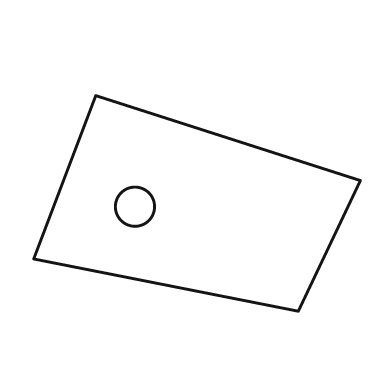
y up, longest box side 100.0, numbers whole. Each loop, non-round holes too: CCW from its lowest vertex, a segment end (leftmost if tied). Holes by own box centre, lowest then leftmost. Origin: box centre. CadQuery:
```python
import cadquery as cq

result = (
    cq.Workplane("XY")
    .moveTo(31.0, -33.0)
    .lineTo(50.0, 7.0)
    .lineTo(-31.0, 33.0)
    .lineTo(-50.0, -17.0)
    .close()
    .moveTo(-19.0, -1.0)
    .circle(6.0)
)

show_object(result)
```